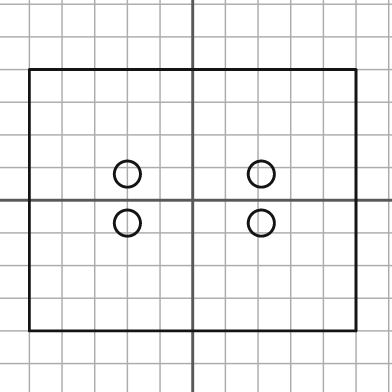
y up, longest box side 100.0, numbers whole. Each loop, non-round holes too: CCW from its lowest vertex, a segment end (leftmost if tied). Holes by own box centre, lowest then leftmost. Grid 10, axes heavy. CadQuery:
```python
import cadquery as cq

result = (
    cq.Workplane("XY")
    .moveTo(-50.0, -40.0)
    .lineTo(50.0, -40.0)
    .lineTo(50.0, 40.0)
    .lineTo(-50.0, 40.0)
    .close()
    .moveTo(-20.0, -7.0)
    .circle(4.0)
    .moveTo(21.0, -7.0)
    .circle(4.0)
    .moveTo(-20.0, 8.0)
    .circle(4.0)
    .moveTo(21.0, 8.0)
    .circle(4.0)
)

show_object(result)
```